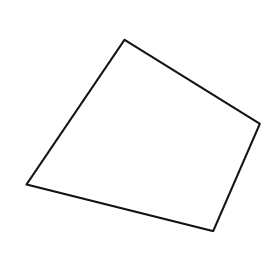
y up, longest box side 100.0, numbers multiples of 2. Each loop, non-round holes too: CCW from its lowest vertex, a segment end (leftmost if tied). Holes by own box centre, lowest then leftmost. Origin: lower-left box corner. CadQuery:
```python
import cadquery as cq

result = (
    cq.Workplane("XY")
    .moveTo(80.0, 0.0)
    .lineTo(100.0, 46.0)
    .lineTo(42.0, 82.0)
    .lineTo(0.0, 20.0)
    .close()
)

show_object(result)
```